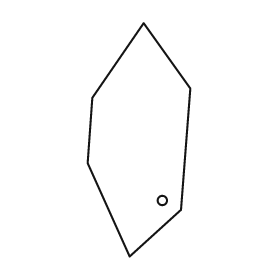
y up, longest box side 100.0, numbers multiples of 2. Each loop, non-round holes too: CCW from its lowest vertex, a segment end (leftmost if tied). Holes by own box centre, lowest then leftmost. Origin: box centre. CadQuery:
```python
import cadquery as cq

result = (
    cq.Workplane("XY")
    .moveTo(-4.0, -50.0)
    .lineTo(18.0, -30.0)
    .lineTo(22.0, 22.0)
    .lineTo(2.0, 50.0)
    .lineTo(-20.0, 18.0)
    .lineTo(-22.0, -10.0)
    .close()
    .moveTo(10.0, -26.0)
    .circle(2.0)
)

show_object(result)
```